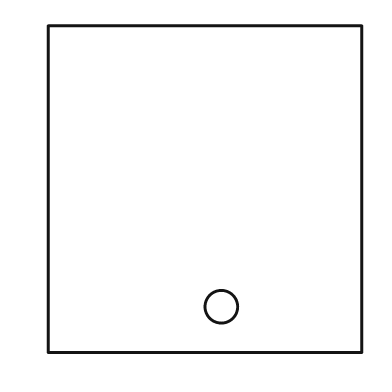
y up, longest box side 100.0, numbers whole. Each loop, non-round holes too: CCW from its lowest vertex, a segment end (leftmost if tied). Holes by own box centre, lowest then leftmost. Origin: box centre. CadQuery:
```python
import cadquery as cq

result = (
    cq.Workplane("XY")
    .moveTo(-48.0, -50.0)
    .lineTo(48.0, -50.0)
    .lineTo(48.0, 50.0)
    .lineTo(-48.0, 50.0)
    .close()
    .moveTo(5.0, -36.0)
    .circle(5.0)
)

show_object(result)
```